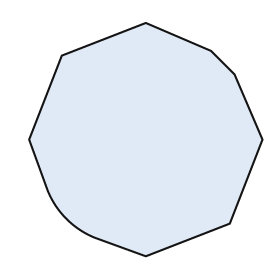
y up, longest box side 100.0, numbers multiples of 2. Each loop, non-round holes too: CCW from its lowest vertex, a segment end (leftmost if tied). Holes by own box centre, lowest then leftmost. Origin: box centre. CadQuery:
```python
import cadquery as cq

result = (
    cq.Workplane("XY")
    .moveTo(0.0, -50.0)
    .lineTo(36.0, -36.0)
    .lineTo(50.0, 0.0)
    .lineTo(38.0, 28.0)
    .lineTo(28.0, 38.0)
    .lineTo(0.0, 50.0)
    .lineTo(-36.0, 36.0)
    .lineTo(-50.0, 0.0)
    .lineTo(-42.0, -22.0)
    .threePointArc((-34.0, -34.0), (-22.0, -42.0))
    .close()
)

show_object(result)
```